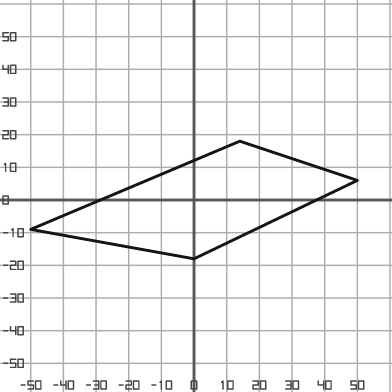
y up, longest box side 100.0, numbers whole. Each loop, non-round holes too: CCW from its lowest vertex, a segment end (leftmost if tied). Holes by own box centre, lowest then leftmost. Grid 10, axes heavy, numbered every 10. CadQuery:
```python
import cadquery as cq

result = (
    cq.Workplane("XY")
    .moveTo(0.0, -18.0)
    .lineTo(50.0, 6.0)
    .lineTo(14.0, 18.0)
    .lineTo(-50.0, -9.0)
    .close()
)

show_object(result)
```